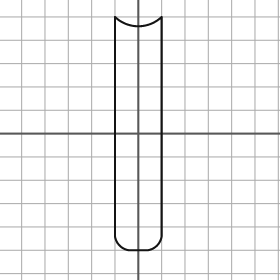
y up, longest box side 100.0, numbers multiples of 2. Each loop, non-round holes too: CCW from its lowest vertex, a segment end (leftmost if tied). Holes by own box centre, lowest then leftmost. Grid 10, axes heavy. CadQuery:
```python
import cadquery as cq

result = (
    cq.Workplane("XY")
    .moveTo(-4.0, -50.0)
    .lineTo(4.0, -50.0)
    .threePointArc((8.0, -48.0), (10.0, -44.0))
    .lineTo(10.0, 50.0)
    .threePointArc((0.0, 46.0), (-10.0, 50.0))
    .lineTo(-10.0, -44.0)
    .threePointArc((-8.0, -48.0), (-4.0, -50.0))
    .close()
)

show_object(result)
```